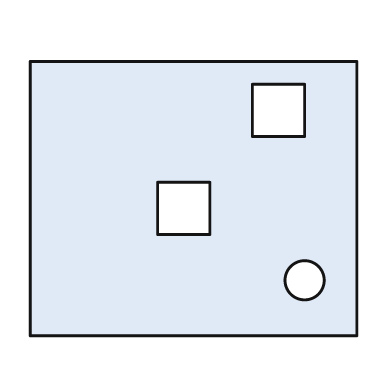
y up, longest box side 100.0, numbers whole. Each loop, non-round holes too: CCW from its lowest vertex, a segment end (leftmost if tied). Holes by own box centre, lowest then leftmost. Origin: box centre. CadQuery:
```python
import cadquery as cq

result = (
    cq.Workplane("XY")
    .moveTo(-50.0, -42.0)
    .lineTo(50.0, -42.0)
    .lineTo(50.0, 42.0)
    .lineTo(-50.0, 42.0)
    .close()
    .moveTo(34.0, -25.0)
    .circle(6.0)
    .moveTo(-11.0, -11.0)
    .lineTo(5.0, -11.0)
    .lineTo(5.0, 5.0)
    .lineTo(-11.0, 5.0)
    .close()
    .moveTo(18.0, 19.0)
    .lineTo(34.0, 19.0)
    .lineTo(34.0, 35.0)
    .lineTo(18.0, 35.0)
    .close()
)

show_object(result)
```